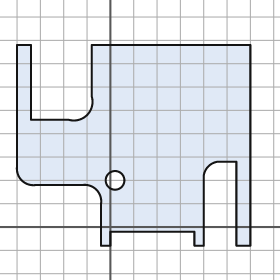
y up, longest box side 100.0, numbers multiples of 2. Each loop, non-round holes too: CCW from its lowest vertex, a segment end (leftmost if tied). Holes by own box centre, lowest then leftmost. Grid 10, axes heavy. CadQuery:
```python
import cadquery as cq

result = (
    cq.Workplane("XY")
    .moveTo(-4.0, -8.0)
    .lineTo(0.0, -8.0)
    .lineTo(0.0, -2.0)
    .lineTo(36.0, -2.0)
    .lineTo(36.0, -8.0)
    .lineTo(40.0, -8.0)
    .lineTo(40.0, 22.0)
    .threePointArc((42.0, 26.0), (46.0, 28.0))
    .lineTo(54.0, 28.0)
    .lineTo(54.0, -8.0)
    .lineTo(60.0, -8.0)
    .lineTo(60.0, 78.0)
    .lineTo(-8.0, 78.0)
    .lineTo(-8.0, 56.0)
    .threePointArc((-10.0, 48.0), (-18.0, 46.0))
    .lineTo(-34.0, 46.0)
    .lineTo(-34.0, 78.0)
    .lineTo(-40.0, 78.0)
    .lineTo(-40.0, 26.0)
    .threePointArc((-38.0, 20.0), (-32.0, 18.0))
    .lineTo(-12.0, 18.0)
    .threePointArc((-6.0, 16.0), (-4.0, 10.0))
    .close()
    .moveTo(2.0, 20.0)
    .circle(4.0)
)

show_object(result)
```